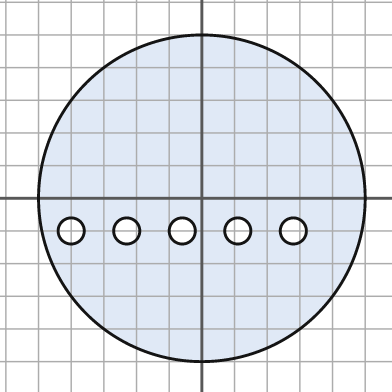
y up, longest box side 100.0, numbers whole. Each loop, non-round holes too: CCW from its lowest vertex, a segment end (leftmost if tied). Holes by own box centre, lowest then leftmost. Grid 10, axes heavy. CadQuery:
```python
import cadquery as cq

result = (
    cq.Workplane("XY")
    .moveTo(0.0, 0.0)
    .circle(50.0)
    .moveTo(-40.0, -10.0)
    .circle(4.0)
    .moveTo(-23.0, -10.0)
    .circle(4.0)
    .moveTo(-6.0, -10.0)
    .circle(4.0)
    .moveTo(11.0, -10.0)
    .circle(4.0)
    .moveTo(28.0, -10.0)
    .circle(4.0)
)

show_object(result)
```